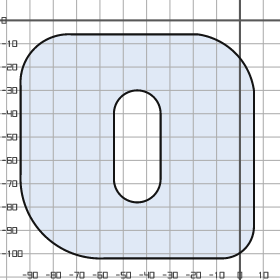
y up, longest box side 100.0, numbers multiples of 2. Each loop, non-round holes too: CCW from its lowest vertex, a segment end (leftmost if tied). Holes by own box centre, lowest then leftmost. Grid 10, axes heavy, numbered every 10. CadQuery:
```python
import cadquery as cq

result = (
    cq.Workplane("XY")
    .moveTo(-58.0, -102.0)
    .lineTo(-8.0, -102.0)
    .threePointArc((2.0, -98.0), (6.0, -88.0))
    .lineTo(6.0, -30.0)
    .threePointArc((-2.0, -14.0), (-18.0, -6.0))
    .lineTo(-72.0, -6.0)
    .threePointArc((-88.0, -12.0), (-94.0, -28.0))
    .lineTo(-94.0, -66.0)
    .threePointArc((-84.0, -92.0), (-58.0, -102.0))
    .close()
    .moveTo(-54.0, -68.0)
    .threePointArc((-44.0, -78.0), (-34.0, -68.0))
    .lineTo(-34.0, -40.0)
    .threePointArc((-44.0, -30.0), (-54.0, -40.0))
    .close()
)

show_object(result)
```